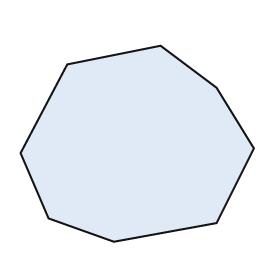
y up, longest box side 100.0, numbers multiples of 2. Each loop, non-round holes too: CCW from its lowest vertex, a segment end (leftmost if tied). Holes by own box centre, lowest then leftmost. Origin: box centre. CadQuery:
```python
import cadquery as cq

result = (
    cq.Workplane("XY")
    .moveTo(-10.0, -42.0)
    .lineTo(34.0, -34.0)
    .lineTo(50.0, -2.0)
    .lineTo(34.0, 24.0)
    .lineTo(10.0, 42.0)
    .lineTo(-30.0, 34.0)
    .lineTo(-50.0, -4.0)
    .lineTo(-38.0, -32.0)
    .close()
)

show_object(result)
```